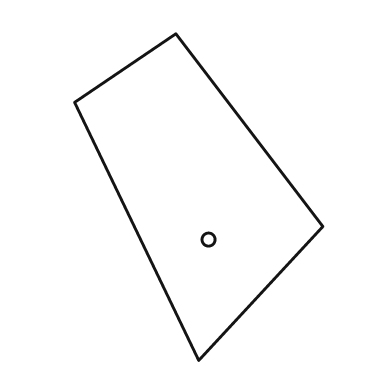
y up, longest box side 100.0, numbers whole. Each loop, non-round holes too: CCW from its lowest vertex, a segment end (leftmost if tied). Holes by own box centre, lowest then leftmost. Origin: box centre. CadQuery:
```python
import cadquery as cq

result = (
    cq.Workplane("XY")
    .moveTo(0.0, -50.0)
    .lineTo(38.0, -9.0)
    .lineTo(-7.0, 50.0)
    .lineTo(-38.0, 29.0)
    .close()
    .moveTo(3.0, -13.0)
    .circle(2.0)
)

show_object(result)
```